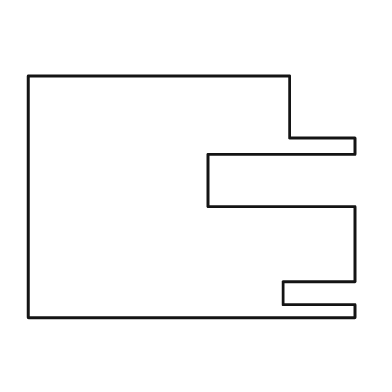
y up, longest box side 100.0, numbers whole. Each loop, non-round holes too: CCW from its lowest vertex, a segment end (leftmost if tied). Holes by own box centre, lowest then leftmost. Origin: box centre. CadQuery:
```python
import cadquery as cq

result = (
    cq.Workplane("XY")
    .moveTo(-50.0, -37.0)
    .lineTo(50.0, -37.0)
    .lineTo(50.0, -33.0)
    .lineTo(28.0, -33.0)
    .lineTo(28.0, -26.0)
    .lineTo(50.0, -26.0)
    .lineTo(50.0, -3.0)
    .lineTo(5.0, -3.0)
    .lineTo(5.0, 13.0)
    .lineTo(50.0, 13.0)
    .lineTo(50.0, 18.0)
    .lineTo(30.0, 18.0)
    .lineTo(30.0, 37.0)
    .lineTo(-50.0, 37.0)
    .close()
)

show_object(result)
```